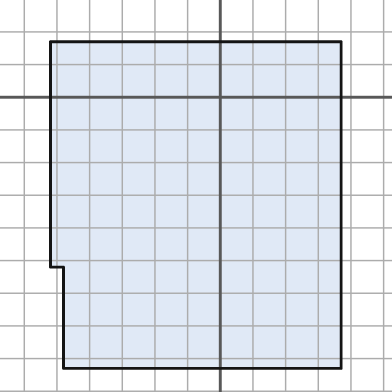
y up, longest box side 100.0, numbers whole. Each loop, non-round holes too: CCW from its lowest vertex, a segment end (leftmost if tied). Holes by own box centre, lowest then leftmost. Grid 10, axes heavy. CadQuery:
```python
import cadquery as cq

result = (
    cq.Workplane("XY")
    .moveTo(-48.0, -83.0)
    .lineTo(37.0, -83.0)
    .lineTo(37.0, 17.0)
    .lineTo(-52.0, 17.0)
    .lineTo(-52.0, -52.0)
    .lineTo(-48.0, -52.0)
    .close()
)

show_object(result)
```